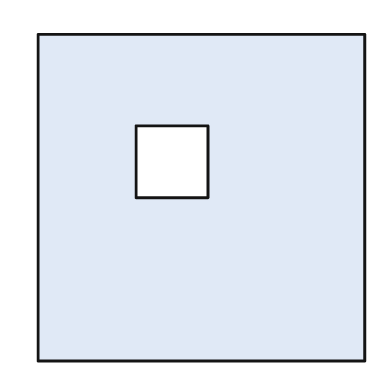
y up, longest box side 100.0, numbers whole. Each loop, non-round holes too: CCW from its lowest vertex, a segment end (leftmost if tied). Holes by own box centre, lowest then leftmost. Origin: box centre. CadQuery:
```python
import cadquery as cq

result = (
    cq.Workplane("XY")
    .moveTo(-50.0, -50.0)
    .lineTo(50.0, -50.0)
    .lineTo(50.0, 50.0)
    .lineTo(-50.0, 50.0)
    .close()
    .moveTo(-20.0, 0.0)
    .lineTo(2.0, 0.0)
    .lineTo(2.0, 22.0)
    .lineTo(-20.0, 22.0)
    .close()
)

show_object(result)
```